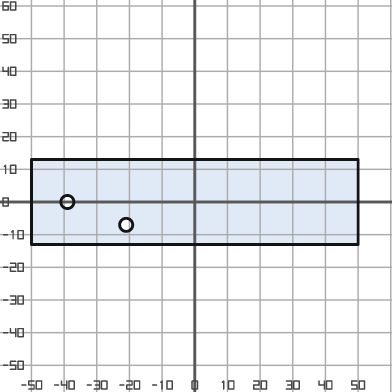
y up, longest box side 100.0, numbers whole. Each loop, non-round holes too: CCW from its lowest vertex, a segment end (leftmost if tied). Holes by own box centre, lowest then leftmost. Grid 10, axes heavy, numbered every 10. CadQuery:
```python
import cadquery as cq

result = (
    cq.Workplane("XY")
    .moveTo(-50.0, -13.0)
    .lineTo(50.0, -13.0)
    .lineTo(50.0, 13.0)
    .lineTo(-50.0, 13.0)
    .close()
    .moveTo(-21.0, -7.0)
    .circle(2.0)
    .moveTo(-39.0, 0.0)
    .circle(2.0)
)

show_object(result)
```